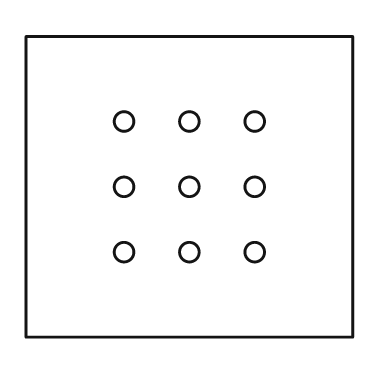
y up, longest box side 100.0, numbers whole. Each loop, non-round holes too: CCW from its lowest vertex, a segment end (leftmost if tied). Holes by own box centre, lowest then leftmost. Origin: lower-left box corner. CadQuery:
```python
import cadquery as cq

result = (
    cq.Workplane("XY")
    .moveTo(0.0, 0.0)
    .lineTo(100.0, 0.0)
    .lineTo(100.0, 92.0)
    .lineTo(0.0, 92.0)
    .close()
    .moveTo(30.0, 26.0)
    .circle(3.0)
    .moveTo(50.0, 26.0)
    .circle(3.0)
    .moveTo(70.0, 26.0)
    .circle(3.0)
    .moveTo(30.0, 46.0)
    .circle(3.0)
    .moveTo(50.0, 46.0)
    .circle(3.0)
    .moveTo(70.0, 46.0)
    .circle(3.0)
    .moveTo(30.0, 66.0)
    .circle(3.0)
    .moveTo(50.0, 66.0)
    .circle(3.0)
    .moveTo(70.0, 66.0)
    .circle(3.0)
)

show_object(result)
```